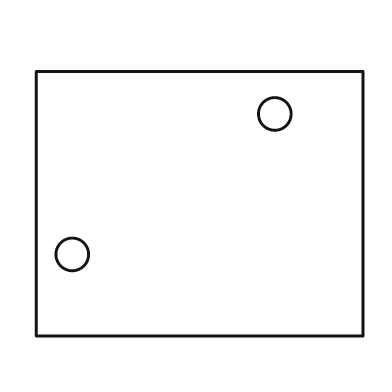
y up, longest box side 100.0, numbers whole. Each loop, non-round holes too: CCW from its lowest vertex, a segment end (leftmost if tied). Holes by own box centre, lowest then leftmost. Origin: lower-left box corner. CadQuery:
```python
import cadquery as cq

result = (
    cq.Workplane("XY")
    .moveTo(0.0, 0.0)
    .lineTo(100.0, 0.0)
    .lineTo(100.0, 81.0)
    .lineTo(0.0, 81.0)
    .close()
    .moveTo(11.0, 25.0)
    .circle(5.0)
    .moveTo(73.0, 68.0)
    .circle(5.0)
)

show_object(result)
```